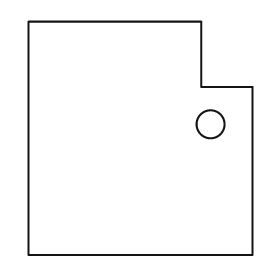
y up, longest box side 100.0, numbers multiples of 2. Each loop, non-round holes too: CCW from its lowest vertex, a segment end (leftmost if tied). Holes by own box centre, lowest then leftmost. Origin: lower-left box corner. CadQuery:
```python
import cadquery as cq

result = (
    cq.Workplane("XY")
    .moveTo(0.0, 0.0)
    .lineTo(96.0, 0.0)
    .lineTo(96.0, 72.0)
    .lineTo(74.0, 72.0)
    .lineTo(74.0, 100.0)
    .lineTo(0.0, 100.0)
    .close()
    .moveTo(78.0, 56.0)
    .circle(6.0)
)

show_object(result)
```